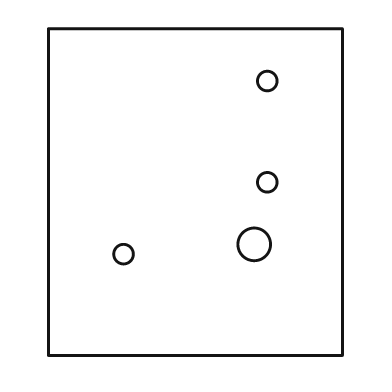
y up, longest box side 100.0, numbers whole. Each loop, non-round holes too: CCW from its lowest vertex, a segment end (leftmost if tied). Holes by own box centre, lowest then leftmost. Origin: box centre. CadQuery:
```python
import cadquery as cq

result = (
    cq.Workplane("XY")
    .moveTo(-45.0, -50.0)
    .lineTo(45.0, -50.0)
    .lineTo(45.0, 50.0)
    .lineTo(-45.0, 50.0)
    .close()
    .moveTo(-22.0, -19.0)
    .circle(3.0)
    .moveTo(18.0, -16.0)
    .circle(5.0)
    .moveTo(22.0, 3.0)
    .circle(3.0)
    .moveTo(22.0, 34.0)
    .circle(3.0)
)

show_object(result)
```